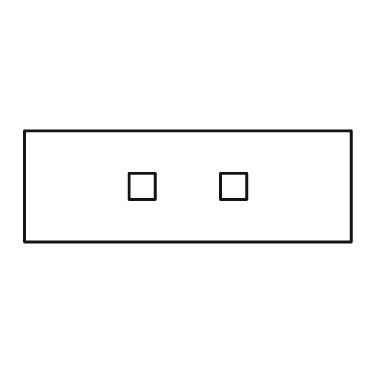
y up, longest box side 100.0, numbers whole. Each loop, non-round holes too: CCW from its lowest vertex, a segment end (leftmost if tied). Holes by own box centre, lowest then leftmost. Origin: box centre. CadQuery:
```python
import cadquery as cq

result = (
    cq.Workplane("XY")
    .moveTo(-50.0, -17.0)
    .lineTo(50.0, -17.0)
    .lineTo(50.0, 17.0)
    .lineTo(-50.0, 17.0)
    .close()
    .moveTo(-18.0, -4.0)
    .lineTo(-10.0, -4.0)
    .lineTo(-10.0, 4.0)
    .lineTo(-18.0, 4.0)
    .close()
    .moveTo(10.0, -4.0)
    .lineTo(18.0, -4.0)
    .lineTo(18.0, 4.0)
    .lineTo(10.0, 4.0)
    .close()
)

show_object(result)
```